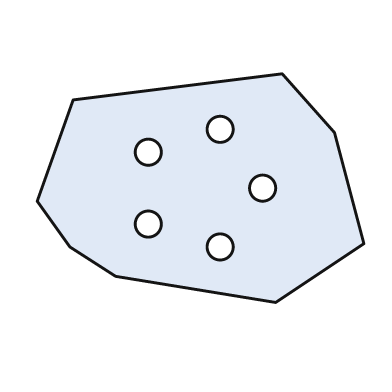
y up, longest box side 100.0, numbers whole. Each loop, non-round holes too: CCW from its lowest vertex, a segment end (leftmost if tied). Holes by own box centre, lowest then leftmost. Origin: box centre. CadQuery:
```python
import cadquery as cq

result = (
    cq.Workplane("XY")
    .moveTo(23.0, -35.0)
    .lineTo(50.0, -17.0)
    .lineTo(41.0, 17.0)
    .lineTo(25.0, 35.0)
    .lineTo(-39.0, 27.0)
    .lineTo(-50.0, -4.0)
    .lineTo(-40.0, -18.0)
    .lineTo(-26.0, -27.0)
    .close()
    .moveTo(6.0, -18.0)
    .circle(4.0)
    .moveTo(-16.0, -11.0)
    .circle(4.0)
    .moveTo(19.0, 0.0)
    .circle(4.0)
    .moveTo(-16.0, 11.0)
    .circle(4.0)
    .moveTo(6.0, 18.0)
    .circle(4.0)
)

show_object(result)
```